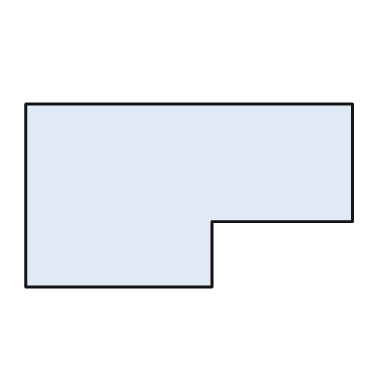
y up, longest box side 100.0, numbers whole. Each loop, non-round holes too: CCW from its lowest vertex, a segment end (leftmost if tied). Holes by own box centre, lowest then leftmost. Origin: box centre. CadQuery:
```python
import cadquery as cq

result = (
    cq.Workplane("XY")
    .moveTo(-50.0, -28.0)
    .lineTo(7.0, -28.0)
    .lineTo(7.0, -8.0)
    .lineTo(50.0, -8.0)
    .lineTo(50.0, 28.0)
    .lineTo(-50.0, 28.0)
    .close()
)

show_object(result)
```